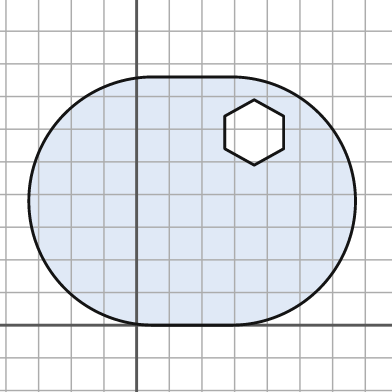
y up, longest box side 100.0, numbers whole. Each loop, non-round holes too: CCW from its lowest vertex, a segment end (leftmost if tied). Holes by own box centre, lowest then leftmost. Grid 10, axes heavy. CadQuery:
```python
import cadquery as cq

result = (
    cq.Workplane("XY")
    .moveTo(5.0, 0.0)
    .lineTo(29.0, 0.0)
    .threePointArc((67.0, 38.0), (29.0, 76.0))
    .lineTo(5.0, 76.0)
    .threePointArc((-33.0, 38.0), (5.0, 0.0))
    .close()
    .moveTo(36.0, 49.0)
    .lineTo(45.0, 54.0)
    .lineTo(45.0, 64.0)
    .lineTo(36.0, 69.0)
    .lineTo(27.0, 64.0)
    .lineTo(27.0, 54.0)
    .close()
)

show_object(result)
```